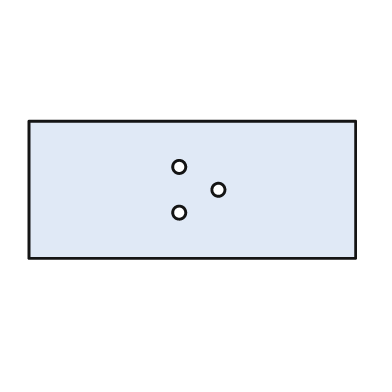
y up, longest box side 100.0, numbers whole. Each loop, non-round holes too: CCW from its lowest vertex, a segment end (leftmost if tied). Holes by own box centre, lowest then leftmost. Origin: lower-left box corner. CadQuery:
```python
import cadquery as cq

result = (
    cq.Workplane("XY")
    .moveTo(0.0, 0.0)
    .lineTo(100.0, 0.0)
    .lineTo(100.0, 42.0)
    .lineTo(0.0, 42.0)
    .close()
    .moveTo(46.0, 14.0)
    .circle(2.0)
    .moveTo(58.0, 21.0)
    .circle(2.0)
    .moveTo(46.0, 28.0)
    .circle(2.0)
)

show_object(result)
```